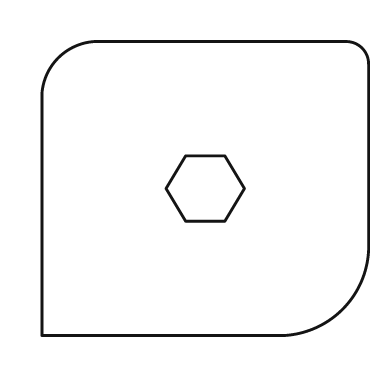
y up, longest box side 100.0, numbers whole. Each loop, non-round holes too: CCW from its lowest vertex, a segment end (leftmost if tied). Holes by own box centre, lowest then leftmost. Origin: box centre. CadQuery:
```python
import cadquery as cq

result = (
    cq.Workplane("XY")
    .moveTo(-50.0, -45.0)
    .lineTo(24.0, -45.0)
    .threePointArc((42.0, -37.0), (50.0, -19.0))
    .lineTo(50.0, 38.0)
    .threePointArc((48.0, 43.0), (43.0, 45.0))
    .lineTo(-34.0, 45.0)
    .threePointArc((-45.0, 40.0), (-50.0, 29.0))
    .close()
    .moveTo(-6.0, -10.0)
    .lineTo(6.0, -10.0)
    .lineTo(12.0, 0.0)
    .lineTo(6.0, 10.0)
    .lineTo(-6.0, 10.0)
    .lineTo(-12.0, 0.0)
    .close()
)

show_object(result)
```